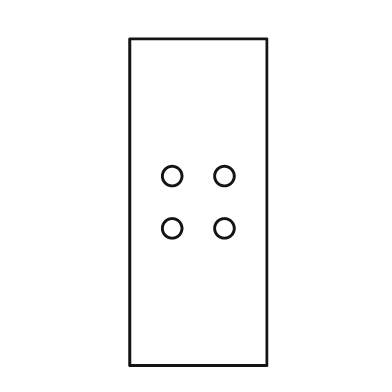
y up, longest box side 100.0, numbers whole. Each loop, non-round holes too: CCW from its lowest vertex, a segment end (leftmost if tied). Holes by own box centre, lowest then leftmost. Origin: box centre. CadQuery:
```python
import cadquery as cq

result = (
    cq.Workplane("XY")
    .moveTo(-21.0, -50.0)
    .lineTo(21.0, -50.0)
    .lineTo(21.0, 50.0)
    .lineTo(-21.0, 50.0)
    .close()
    .moveTo(-8.0, -8.0)
    .circle(3.0)
    .moveTo(8.0, -8.0)
    .circle(3.0)
    .moveTo(-8.0, 8.0)
    .circle(3.0)
    .moveTo(8.0, 8.0)
    .circle(3.0)
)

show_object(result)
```